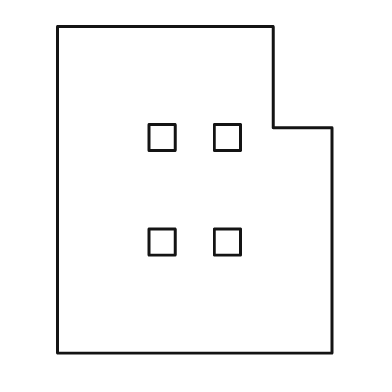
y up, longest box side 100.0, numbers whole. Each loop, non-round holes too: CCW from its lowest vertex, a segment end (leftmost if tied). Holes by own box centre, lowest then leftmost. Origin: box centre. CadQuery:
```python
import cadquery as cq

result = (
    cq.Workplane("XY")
    .moveTo(-42.0, -50.0)
    .lineTo(42.0, -50.0)
    .lineTo(42.0, 19.0)
    .lineTo(24.0, 19.0)
    .lineTo(24.0, 50.0)
    .lineTo(-42.0, 50.0)
    .close()
    .moveTo(-14.0, -20.0)
    .lineTo(-6.0, -20.0)
    .lineTo(-6.0, -12.0)
    .lineTo(-14.0, -12.0)
    .close()
    .moveTo(6.0, -20.0)
    .lineTo(14.0, -20.0)
    .lineTo(14.0, -12.0)
    .lineTo(6.0, -12.0)
    .close()
    .moveTo(-14.0, 12.0)
    .lineTo(-6.0, 12.0)
    .lineTo(-6.0, 20.0)
    .lineTo(-14.0, 20.0)
    .close()
    .moveTo(6.0, 12.0)
    .lineTo(14.0, 12.0)
    .lineTo(14.0, 20.0)
    .lineTo(6.0, 20.0)
    .close()
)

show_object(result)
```